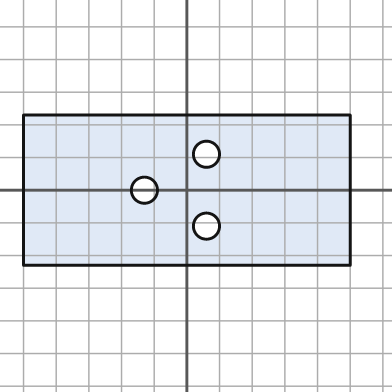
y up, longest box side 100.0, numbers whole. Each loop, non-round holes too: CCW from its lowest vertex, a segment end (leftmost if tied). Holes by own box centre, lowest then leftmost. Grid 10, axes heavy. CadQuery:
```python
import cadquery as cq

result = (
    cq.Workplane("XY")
    .moveTo(-50.0, -23.0)
    .lineTo(50.0, -23.0)
    .lineTo(50.0, 23.0)
    .lineTo(-50.0, 23.0)
    .close()
    .moveTo(6.0, -11.0)
    .circle(4.0)
    .moveTo(-13.0, 0.0)
    .circle(4.0)
    .moveTo(6.0, 11.0)
    .circle(4.0)
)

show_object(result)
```